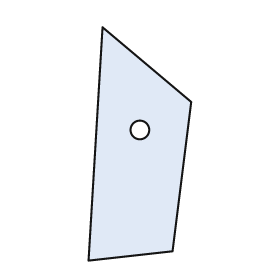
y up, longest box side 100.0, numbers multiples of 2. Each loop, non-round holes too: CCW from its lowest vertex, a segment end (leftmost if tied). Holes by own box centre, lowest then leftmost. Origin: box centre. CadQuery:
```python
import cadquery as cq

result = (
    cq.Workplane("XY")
    .moveTo(-22.0, -50.0)
    .lineTo(14.0, -46.0)
    .lineTo(22.0, 18.0)
    .lineTo(-16.0, 50.0)
    .close()
    .moveTo(0.0, 6.0)
    .circle(4.0)
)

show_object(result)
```